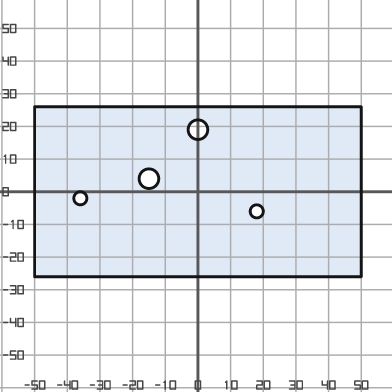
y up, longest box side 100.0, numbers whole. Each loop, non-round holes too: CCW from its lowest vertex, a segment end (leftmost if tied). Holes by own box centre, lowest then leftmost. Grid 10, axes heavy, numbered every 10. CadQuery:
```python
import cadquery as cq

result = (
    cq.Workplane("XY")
    .moveTo(-50.0, -26.0)
    .lineTo(50.0, -26.0)
    .lineTo(50.0, 26.0)
    .lineTo(-50.0, 26.0)
    .close()
    .moveTo(18.0, -6.0)
    .circle(2.0)
    .moveTo(-36.0, -2.0)
    .circle(2.0)
    .moveTo(-15.0, 4.0)
    .circle(3.0)
    .moveTo(0.0, 19.0)
    .circle(3.0)
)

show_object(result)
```